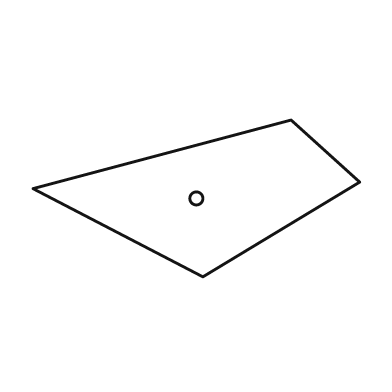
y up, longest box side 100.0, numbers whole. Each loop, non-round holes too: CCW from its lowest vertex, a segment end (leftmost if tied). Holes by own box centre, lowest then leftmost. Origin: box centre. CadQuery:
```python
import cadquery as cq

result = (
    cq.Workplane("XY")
    .moveTo(2.0, -24.0)
    .lineTo(50.0, 5.0)
    .lineTo(29.0, 24.0)
    .lineTo(-50.0, 3.0)
    .close()
    .moveTo(0.0, 0.0)
    .circle(2.0)
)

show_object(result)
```